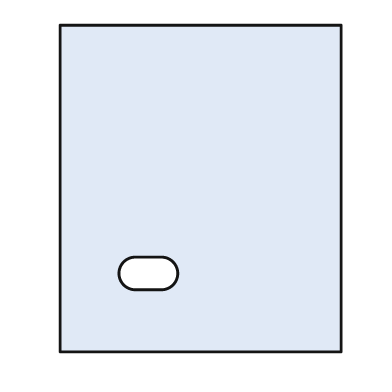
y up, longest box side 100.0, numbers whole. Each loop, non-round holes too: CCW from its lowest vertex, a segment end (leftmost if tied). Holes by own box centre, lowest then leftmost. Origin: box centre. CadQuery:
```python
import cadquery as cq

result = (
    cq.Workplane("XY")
    .moveTo(-43.0, -50.0)
    .lineTo(43.0, -50.0)
    .lineTo(43.0, 50.0)
    .lineTo(-43.0, 50.0)
    .close()
    .moveTo(-20.0, -31.0)
    .lineTo(-12.0, -31.0)
    .threePointArc((-7.0, -26.0), (-12.0, -21.0))
    .lineTo(-20.0, -21.0)
    .threePointArc((-25.0, -26.0), (-20.0, -31.0))
    .close()
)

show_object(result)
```